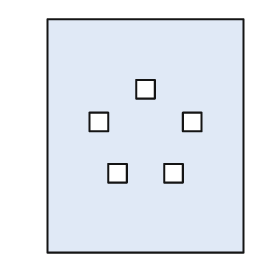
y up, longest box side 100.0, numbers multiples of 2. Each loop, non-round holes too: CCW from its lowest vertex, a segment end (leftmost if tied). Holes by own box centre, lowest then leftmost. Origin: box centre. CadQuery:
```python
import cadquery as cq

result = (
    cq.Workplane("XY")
    .moveTo(-42.0, -50.0)
    .lineTo(42.0, -50.0)
    .lineTo(42.0, 50.0)
    .lineTo(-42.0, 50.0)
    .close()
    .moveTo(-16.0, -20.0)
    .lineTo(-8.0, -20.0)
    .lineTo(-8.0, -12.0)
    .lineTo(-16.0, -12.0)
    .close()
    .moveTo(8.0, -20.0)
    .lineTo(16.0, -20.0)
    .lineTo(16.0, -12.0)
    .lineTo(8.0, -12.0)
    .close()
    .moveTo(-24.0, 2.0)
    .lineTo(-16.0, 2.0)
    .lineTo(-16.0, 10.0)
    .lineTo(-24.0, 10.0)
    .close()
    .moveTo(16.0, 2.0)
    .lineTo(24.0, 2.0)
    .lineTo(24.0, 10.0)
    .lineTo(16.0, 10.0)
    .close()
    .moveTo(-4.0, 16.0)
    .lineTo(4.0, 16.0)
    .lineTo(4.0, 24.0)
    .lineTo(-4.0, 24.0)
    .close()
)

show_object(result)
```